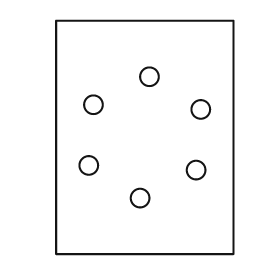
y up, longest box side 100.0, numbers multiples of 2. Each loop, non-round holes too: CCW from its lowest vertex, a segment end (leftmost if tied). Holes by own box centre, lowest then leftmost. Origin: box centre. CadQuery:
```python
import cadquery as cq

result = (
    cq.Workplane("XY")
    .moveTo(-38.0, -50.0)
    .lineTo(38.0, -50.0)
    .lineTo(38.0, 50.0)
    .lineTo(-38.0, 50.0)
    .close()
    .moveTo(-2.0, -26.0)
    .circle(4.0)
    .moveTo(22.0, -14.0)
    .circle(4.0)
    .moveTo(-24.0, -12.0)
    .circle(4.0)
    .moveTo(24.0, 12.0)
    .circle(4.0)
    .moveTo(-22.0, 14.0)
    .circle(4.0)
    .moveTo(2.0, 26.0)
    .circle(4.0)
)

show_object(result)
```